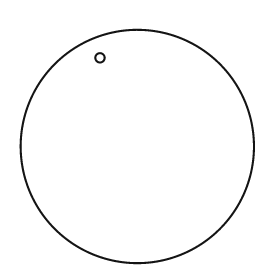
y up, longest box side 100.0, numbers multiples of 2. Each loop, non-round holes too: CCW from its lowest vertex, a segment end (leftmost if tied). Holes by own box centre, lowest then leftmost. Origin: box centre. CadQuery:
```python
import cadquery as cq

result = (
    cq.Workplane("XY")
    .moveTo(0.0, 0.0)
    .circle(50.0)
    .moveTo(-16.0, 38.0)
    .circle(2.0)
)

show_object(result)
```